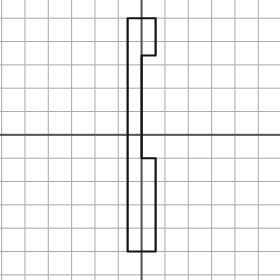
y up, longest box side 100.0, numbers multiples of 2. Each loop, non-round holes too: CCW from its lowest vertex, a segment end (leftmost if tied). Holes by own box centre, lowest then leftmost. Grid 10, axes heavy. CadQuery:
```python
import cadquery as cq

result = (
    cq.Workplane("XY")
    .moveTo(-6.0, -50.0)
    .lineTo(6.0, -50.0)
    .lineTo(6.0, -10.0)
    .lineTo(0.0, -10.0)
    .lineTo(0.0, 34.0)
    .lineTo(6.0, 34.0)
    .lineTo(6.0, 50.0)
    .lineTo(-6.0, 50.0)
    .close()
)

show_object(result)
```